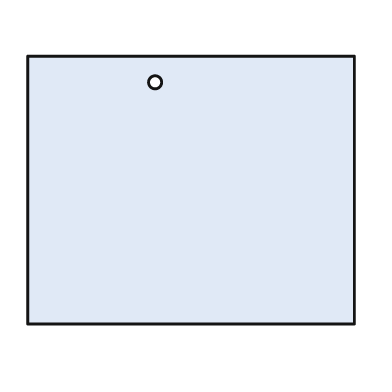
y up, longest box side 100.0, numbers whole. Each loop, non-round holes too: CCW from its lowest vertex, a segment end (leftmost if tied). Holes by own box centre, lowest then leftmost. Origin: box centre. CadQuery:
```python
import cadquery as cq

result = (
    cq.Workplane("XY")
    .moveTo(-50.0, -41.0)
    .lineTo(50.0, -41.0)
    .lineTo(50.0, 41.0)
    .lineTo(-50.0, 41.0)
    .close()
    .moveTo(-11.0, 33.0)
    .circle(2.0)
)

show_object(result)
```